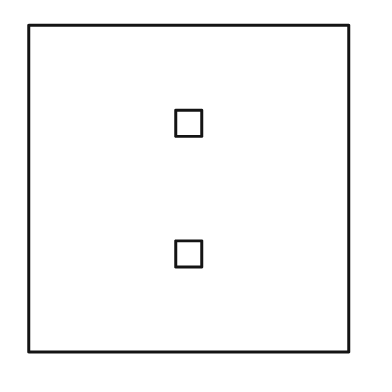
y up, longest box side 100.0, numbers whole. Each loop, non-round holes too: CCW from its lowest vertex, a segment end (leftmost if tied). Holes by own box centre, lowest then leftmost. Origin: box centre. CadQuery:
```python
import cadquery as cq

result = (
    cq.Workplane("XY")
    .moveTo(-49.0, -50.0)
    .lineTo(49.0, -50.0)
    .lineTo(49.0, 50.0)
    .lineTo(-49.0, 50.0)
    .close()
    .moveTo(-4.0, -24.0)
    .lineTo(4.0, -24.0)
    .lineTo(4.0, -16.0)
    .lineTo(-4.0, -16.0)
    .close()
    .moveTo(-4.0, 16.0)
    .lineTo(4.0, 16.0)
    .lineTo(4.0, 24.0)
    .lineTo(-4.0, 24.0)
    .close()
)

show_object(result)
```